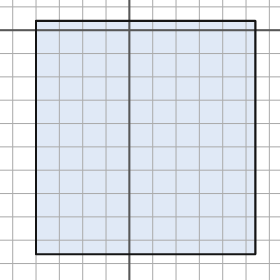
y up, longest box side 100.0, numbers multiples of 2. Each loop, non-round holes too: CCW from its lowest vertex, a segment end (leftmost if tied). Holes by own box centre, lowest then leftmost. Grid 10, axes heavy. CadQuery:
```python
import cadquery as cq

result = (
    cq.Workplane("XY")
    .moveTo(-40.0, -96.0)
    .lineTo(54.0, -96.0)
    .lineTo(54.0, 4.0)
    .lineTo(-40.0, 4.0)
    .close()
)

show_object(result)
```